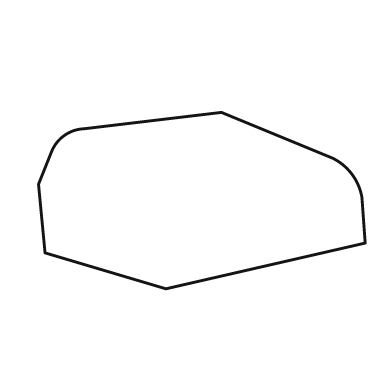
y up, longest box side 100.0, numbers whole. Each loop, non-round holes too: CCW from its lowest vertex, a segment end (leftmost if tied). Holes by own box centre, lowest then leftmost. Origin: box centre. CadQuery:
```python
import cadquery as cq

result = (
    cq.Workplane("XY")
    .moveTo(-11.0, -27.0)
    .lineTo(50.0, -13.0)
    .lineTo(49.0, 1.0)
    .threePointArc((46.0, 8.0), (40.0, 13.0))
    .lineTo(6.0, 27.0)
    .lineTo(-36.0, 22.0)
    .threePointArc((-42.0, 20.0), (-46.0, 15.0))
    .lineTo(-50.0, 5.0)
    .lineTo(-48.0, -16.0)
    .close()
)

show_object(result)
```